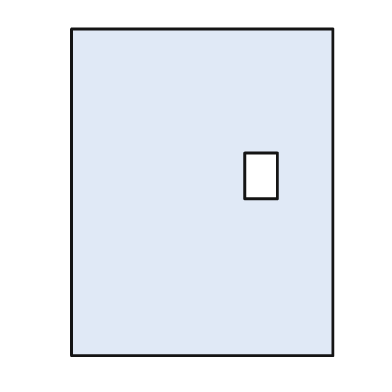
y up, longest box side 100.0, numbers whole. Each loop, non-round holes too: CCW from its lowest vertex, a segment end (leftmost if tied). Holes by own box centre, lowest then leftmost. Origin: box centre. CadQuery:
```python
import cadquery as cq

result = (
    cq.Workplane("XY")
    .moveTo(-40.0, -50.0)
    .lineTo(40.0, -50.0)
    .lineTo(40.0, 50.0)
    .lineTo(-40.0, 50.0)
    .close()
    .moveTo(13.0, -2.0)
    .lineTo(23.0, -2.0)
    .lineTo(23.0, 12.0)
    .lineTo(13.0, 12.0)
    .close()
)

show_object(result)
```